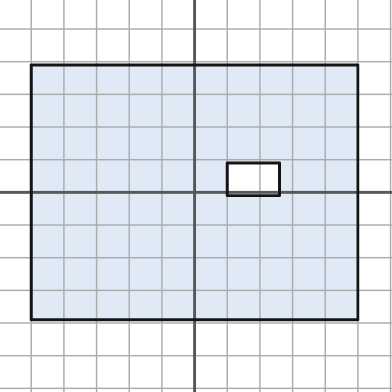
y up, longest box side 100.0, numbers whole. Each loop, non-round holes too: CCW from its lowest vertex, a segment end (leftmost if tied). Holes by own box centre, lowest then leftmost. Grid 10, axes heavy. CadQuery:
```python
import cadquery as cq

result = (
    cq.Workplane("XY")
    .moveTo(-50.0, -39.0)
    .lineTo(50.0, -39.0)
    .lineTo(50.0, 39.0)
    .lineTo(-50.0, 39.0)
    .close()
    .moveTo(10.0, -1.0)
    .lineTo(26.0, -1.0)
    .lineTo(26.0, 9.0)
    .lineTo(10.0, 9.0)
    .close()
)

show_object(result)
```